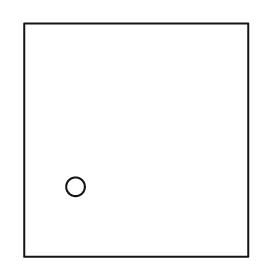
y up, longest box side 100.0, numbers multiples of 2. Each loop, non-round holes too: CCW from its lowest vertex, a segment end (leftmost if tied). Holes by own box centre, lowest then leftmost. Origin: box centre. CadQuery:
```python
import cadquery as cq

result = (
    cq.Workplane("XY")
    .moveTo(-48.0, -50.0)
    .lineTo(48.0, -50.0)
    .lineTo(48.0, 50.0)
    .lineTo(-48.0, 50.0)
    .close()
    .moveTo(-26.0, -20.0)
    .circle(4.0)
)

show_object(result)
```